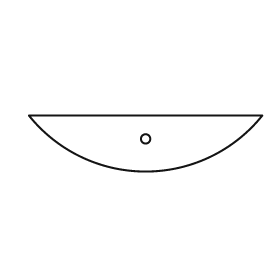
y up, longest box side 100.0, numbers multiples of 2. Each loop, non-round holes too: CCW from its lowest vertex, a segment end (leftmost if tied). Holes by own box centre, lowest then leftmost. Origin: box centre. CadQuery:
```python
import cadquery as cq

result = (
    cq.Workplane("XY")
    .moveTo(-50.0, 12.0)
    .threePointArc((0.0, -12.0), (50.0, 12.0))
    .close()
    .moveTo(0.0, 2.0)
    .circle(2.0)
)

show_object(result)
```